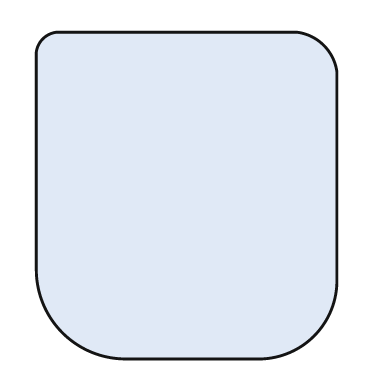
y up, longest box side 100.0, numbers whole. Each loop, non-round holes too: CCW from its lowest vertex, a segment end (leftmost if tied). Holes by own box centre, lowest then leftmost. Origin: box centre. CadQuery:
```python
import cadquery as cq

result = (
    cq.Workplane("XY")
    .moveTo(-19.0, -50.0)
    .lineTo(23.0, -50.0)
    .threePointArc((39.0, -43.0), (46.0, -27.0))
    .lineTo(46.0, 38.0)
    .threePointArc((42.0, 46.0), (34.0, 50.0))
    .lineTo(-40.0, 50.0)
    .threePointArc((-44.0, 48.0), (-46.0, 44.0))
    .lineTo(-46.0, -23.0)
    .threePointArc((-38.0, -42.0), (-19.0, -50.0))
    .close()
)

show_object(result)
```